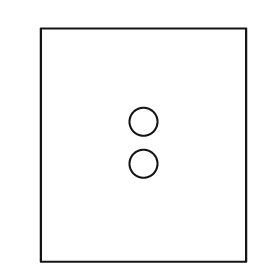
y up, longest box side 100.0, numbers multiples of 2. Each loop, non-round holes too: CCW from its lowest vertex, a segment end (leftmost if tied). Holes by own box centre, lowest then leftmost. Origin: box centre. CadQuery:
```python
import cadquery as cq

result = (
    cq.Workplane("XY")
    .moveTo(-44.0, -50.0)
    .lineTo(44.0, -50.0)
    .lineTo(44.0, 50.0)
    .lineTo(-44.0, 50.0)
    .close()
    .moveTo(0.0, -8.0)
    .circle(6.0)
    .moveTo(0.0, 10.0)
    .circle(6.0)
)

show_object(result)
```